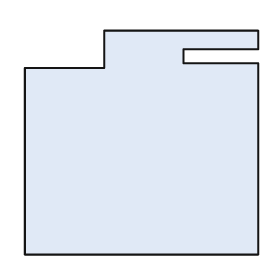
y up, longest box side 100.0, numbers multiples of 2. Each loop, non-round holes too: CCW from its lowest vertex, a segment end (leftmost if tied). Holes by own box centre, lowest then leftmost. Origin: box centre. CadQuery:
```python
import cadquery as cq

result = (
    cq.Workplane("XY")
    .moveTo(-50.0, -48.0)
    .lineTo(50.0, -48.0)
    .lineTo(50.0, 34.0)
    .lineTo(18.0, 34.0)
    .lineTo(18.0, 40.0)
    .lineTo(50.0, 40.0)
    .lineTo(50.0, 48.0)
    .lineTo(-16.0, 48.0)
    .lineTo(-16.0, 32.0)
    .lineTo(-50.0, 32.0)
    .close()
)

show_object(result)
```